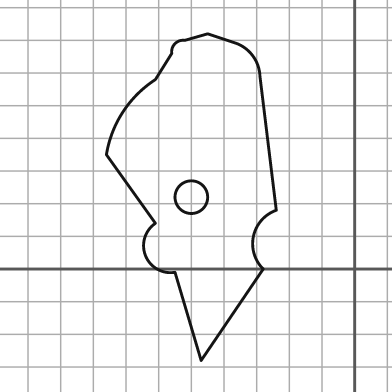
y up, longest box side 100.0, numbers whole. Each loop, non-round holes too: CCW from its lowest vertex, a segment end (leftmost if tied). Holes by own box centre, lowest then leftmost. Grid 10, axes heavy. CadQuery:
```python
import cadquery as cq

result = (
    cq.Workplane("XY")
    .moveTo(-47.0, -28.0)
    .lineTo(-28.0, 0.0)
    .threePointArc((-31.0, 10.0), (-24.0, 18.0))
    .lineTo(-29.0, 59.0)
    .threePointArc((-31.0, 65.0), (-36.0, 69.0))
    .lineTo(-45.0, 72.0)
    .lineTo(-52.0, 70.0)
    .threePointArc((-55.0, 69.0), (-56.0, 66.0))
    .lineTo(-61.0, 58.0)
    .threePointArc((-71.0, 48.0), (-76.0, 35.0))
    .lineTo(-61.0, 14.0)
    .threePointArc((-64.0, 4.0), (-55.0, -1.0))
    .close()
    .moveTo(-50.0, 22.0)
    .circle(5.0)
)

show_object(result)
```